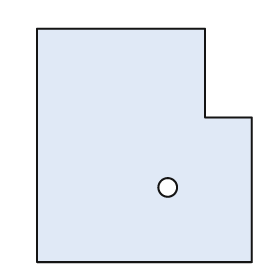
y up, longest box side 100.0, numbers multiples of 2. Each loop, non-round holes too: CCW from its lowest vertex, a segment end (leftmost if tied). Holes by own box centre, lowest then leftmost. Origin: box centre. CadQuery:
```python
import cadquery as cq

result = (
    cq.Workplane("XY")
    .moveTo(-46.0, -50.0)
    .lineTo(46.0, -50.0)
    .lineTo(46.0, 12.0)
    .lineTo(26.0, 12.0)
    .lineTo(26.0, 50.0)
    .lineTo(-46.0, 50.0)
    .close()
    .moveTo(10.0, -18.0)
    .circle(4.0)
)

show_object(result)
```